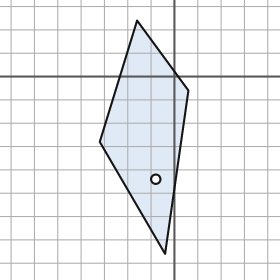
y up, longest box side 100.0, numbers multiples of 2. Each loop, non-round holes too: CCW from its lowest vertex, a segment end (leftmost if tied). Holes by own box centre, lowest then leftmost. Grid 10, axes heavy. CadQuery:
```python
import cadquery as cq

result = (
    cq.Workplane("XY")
    .moveTo(-4.0, -76.0)
    .lineTo(6.0, -6.0)
    .lineTo(-16.0, 24.0)
    .lineTo(-32.0, -28.0)
    .close()
    .moveTo(-8.0, -44.0)
    .circle(2.0)
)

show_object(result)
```